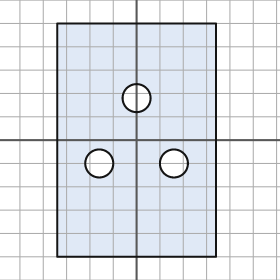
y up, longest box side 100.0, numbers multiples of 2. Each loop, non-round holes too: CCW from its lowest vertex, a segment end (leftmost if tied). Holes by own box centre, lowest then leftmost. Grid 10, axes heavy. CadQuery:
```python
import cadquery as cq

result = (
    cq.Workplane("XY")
    .moveTo(-34.0, -50.0)
    .lineTo(34.0, -50.0)
    .lineTo(34.0, 50.0)
    .lineTo(-34.0, 50.0)
    .close()
    .moveTo(-16.0, -10.0)
    .circle(6.0)
    .moveTo(16.0, -10.0)
    .circle(6.0)
    .moveTo(0.0, 18.0)
    .circle(6.0)
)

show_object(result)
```